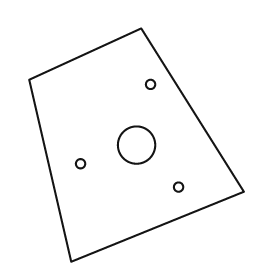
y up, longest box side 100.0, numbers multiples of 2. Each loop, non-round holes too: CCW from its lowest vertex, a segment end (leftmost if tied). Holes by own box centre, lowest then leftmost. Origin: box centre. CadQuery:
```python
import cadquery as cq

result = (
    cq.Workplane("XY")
    .moveTo(-28.0, -50.0)
    .lineTo(46.0, -20.0)
    .lineTo(2.0, 50.0)
    .lineTo(-46.0, 28.0)
    .close()
    .moveTo(18.0, -18.0)
    .circle(2.0)
    .moveTo(-24.0, -8.0)
    .circle(2.0)
    .moveTo(0.0, 0.0)
    .circle(8.0)
    .moveTo(6.0, 26.0)
    .circle(2.0)
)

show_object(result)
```